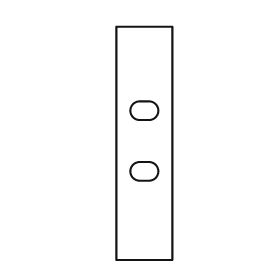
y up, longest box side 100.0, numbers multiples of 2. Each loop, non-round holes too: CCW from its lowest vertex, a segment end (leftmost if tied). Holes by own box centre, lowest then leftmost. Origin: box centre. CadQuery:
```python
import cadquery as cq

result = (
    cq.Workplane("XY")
    .moveTo(-12.0, -50.0)
    .lineTo(12.0, -50.0)
    .lineTo(12.0, 50.0)
    .lineTo(-12.0, 50.0)
    .close()
    .moveTo(-2.0, -16.0)
    .lineTo(2.0, -16.0)
    .threePointArc((6.0, -12.0), (2.0, -8.0))
    .lineTo(-2.0, -8.0)
    .threePointArc((-6.0, -12.0), (-2.0, -16.0))
    .close()
    .moveTo(-2.0, 10.0)
    .lineTo(2.0, 10.0)
    .threePointArc((6.0, 14.0), (2.0, 18.0))
    .lineTo(-2.0, 18.0)
    .threePointArc((-6.0, 14.0), (-2.0, 10.0))
    .close()
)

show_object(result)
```